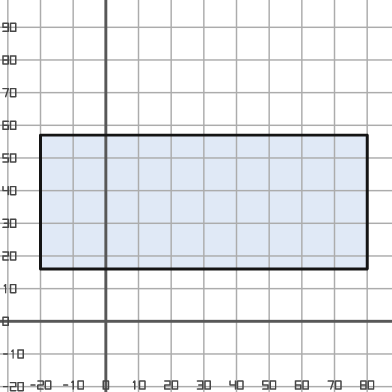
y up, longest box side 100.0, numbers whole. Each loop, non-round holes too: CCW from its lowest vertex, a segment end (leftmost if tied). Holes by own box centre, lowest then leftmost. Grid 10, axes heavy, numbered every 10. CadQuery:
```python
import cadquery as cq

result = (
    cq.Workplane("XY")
    .moveTo(-20.0, 16.0)
    .lineTo(80.0, 16.0)
    .lineTo(80.0, 57.0)
    .lineTo(-20.0, 57.0)
    .close()
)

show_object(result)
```